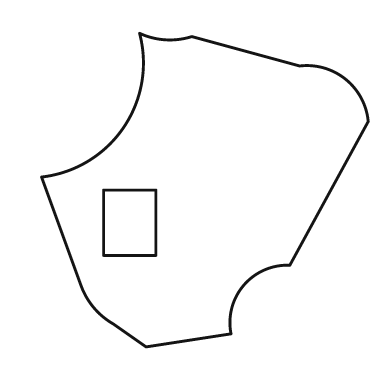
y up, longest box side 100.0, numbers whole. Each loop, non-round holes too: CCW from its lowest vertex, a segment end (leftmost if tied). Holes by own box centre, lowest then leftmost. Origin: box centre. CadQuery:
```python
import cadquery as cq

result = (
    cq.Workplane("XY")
    .moveTo(-18.0, -48.0)
    .lineTo(8.0, -44.0)
    .threePointArc((12.0, -29.0), (26.0, -23.0))
    .lineTo(50.0, 21.0)
    .threePointArc((43.0, 34.0), (29.0, 38.0))
    .lineTo(-4.0, 47.0)
    .threePointArc((-12.0, 46.0), (-20.0, 48.0))
    .threePointArc((-25.0, 19.0), (-50.0, 4.0))
    .lineTo(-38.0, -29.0)
    .threePointArc((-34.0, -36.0), (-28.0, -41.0))
    .close()
    .moveTo(-31.0, -20.0)
    .lineTo(-15.0, -20.0)
    .lineTo(-15.0, 0.0)
    .lineTo(-31.0, 0.0)
    .close()
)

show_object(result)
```